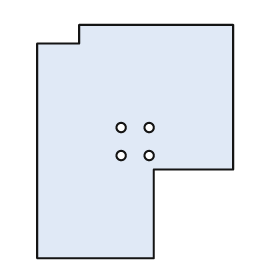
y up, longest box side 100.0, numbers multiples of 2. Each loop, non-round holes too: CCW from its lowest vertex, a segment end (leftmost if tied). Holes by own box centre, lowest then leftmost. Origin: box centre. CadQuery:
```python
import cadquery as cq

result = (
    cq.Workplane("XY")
    .moveTo(-42.0, -50.0)
    .lineTo(8.0, -50.0)
    .lineTo(8.0, -12.0)
    .lineTo(42.0, -12.0)
    .lineTo(42.0, 50.0)
    .lineTo(-24.0, 50.0)
    .lineTo(-24.0, 42.0)
    .lineTo(-42.0, 42.0)
    .close()
    .moveTo(-6.0, -6.0)
    .circle(2.0)
    .moveTo(6.0, -6.0)
    .circle(2.0)
    .moveTo(-6.0, 6.0)
    .circle(2.0)
    .moveTo(6.0, 6.0)
    .circle(2.0)
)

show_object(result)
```